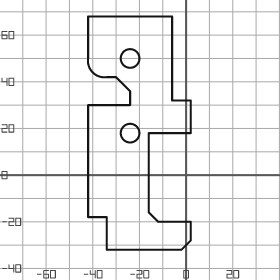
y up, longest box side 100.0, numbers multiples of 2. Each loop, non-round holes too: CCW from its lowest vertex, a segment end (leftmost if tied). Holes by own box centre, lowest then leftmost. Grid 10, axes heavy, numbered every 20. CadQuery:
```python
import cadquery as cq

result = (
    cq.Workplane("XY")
    .moveTo(-34.0, -32.0)
    .lineTo(-2.0, -32.0)
    .lineTo(2.0, -28.0)
    .lineTo(2.0, -20.0)
    .lineTo(-12.0, -20.0)
    .lineTo(-16.0, -16.0)
    .lineTo(-16.0, 18.0)
    .lineTo(2.0, 18.0)
    .lineTo(2.0, 32.0)
    .lineTo(-6.0, 32.0)
    .lineTo(-6.0, 68.0)
    .lineTo(-42.0, 68.0)
    .lineTo(-42.0, 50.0)
    .threePointArc((-40.0, 44.0), (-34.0, 42.0))
    .lineTo(-30.0, 42.0)
    .lineTo(-24.0, 36.0)
    .lineTo(-24.0, 30.0)
    .lineTo(-42.0, 30.0)
    .lineTo(-42.0, -18.0)
    .lineTo(-34.0, -18.0)
    .close()
    .moveTo(-24.0, 18.0)
    .circle(4.0)
    .moveTo(-24.0, 50.0)
    .circle(4.0)
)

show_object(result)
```